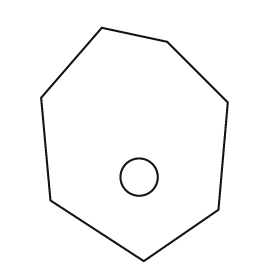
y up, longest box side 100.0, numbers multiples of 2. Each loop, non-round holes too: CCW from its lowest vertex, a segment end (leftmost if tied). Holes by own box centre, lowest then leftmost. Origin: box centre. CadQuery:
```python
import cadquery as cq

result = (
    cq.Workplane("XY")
    .moveTo(4.0, -50.0)
    .lineTo(36.0, -28.0)
    .lineTo(40.0, 18.0)
    .lineTo(14.0, 44.0)
    .lineTo(-14.0, 50.0)
    .lineTo(-40.0, 20.0)
    .lineTo(-36.0, -24.0)
    .close()
    .moveTo(2.0, -14.0)
    .circle(8.0)
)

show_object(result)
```